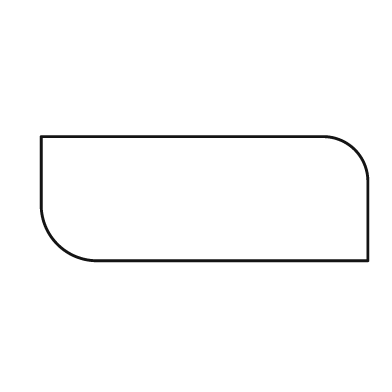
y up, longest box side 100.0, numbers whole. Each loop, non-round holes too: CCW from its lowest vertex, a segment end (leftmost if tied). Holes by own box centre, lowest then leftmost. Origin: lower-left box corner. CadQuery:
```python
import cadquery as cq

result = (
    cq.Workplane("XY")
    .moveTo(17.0, 0.0)
    .lineTo(100.0, 0.0)
    .lineTo(100.0, 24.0)
    .threePointArc((96.0, 34.0), (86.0, 38.0))
    .lineTo(0.0, 38.0)
    .lineTo(0.0, 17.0)
    .threePointArc((5.0, 5.0), (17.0, 0.0))
    .close()
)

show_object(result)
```